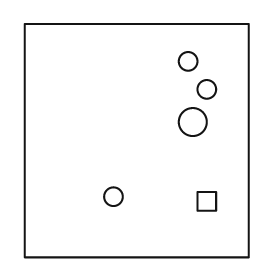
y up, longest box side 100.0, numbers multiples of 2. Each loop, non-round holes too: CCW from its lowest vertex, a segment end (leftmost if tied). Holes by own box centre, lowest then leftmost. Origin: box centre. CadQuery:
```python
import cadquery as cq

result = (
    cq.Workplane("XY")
    .moveTo(-48.0, -50.0)
    .lineTo(48.0, -50.0)
    .lineTo(48.0, 50.0)
    .lineTo(-48.0, 50.0)
    .close()
    .moveTo(26.0, -30.0)
    .lineTo(34.0, -30.0)
    .lineTo(34.0, -22.0)
    .lineTo(26.0, -22.0)
    .close()
    .moveTo(-10.0, -24.0)
    .circle(4.0)
    .moveTo(24.0, 8.0)
    .circle(6.0)
    .moveTo(30.0, 22.0)
    .circle(4.0)
    .moveTo(22.0, 34.0)
    .circle(4.0)
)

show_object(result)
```